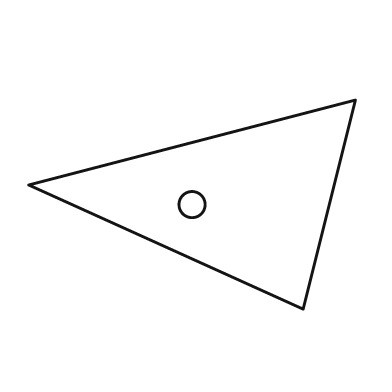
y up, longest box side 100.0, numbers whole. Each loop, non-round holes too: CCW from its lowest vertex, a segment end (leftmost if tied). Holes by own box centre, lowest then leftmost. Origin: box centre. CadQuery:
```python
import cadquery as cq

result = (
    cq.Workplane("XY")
    .moveTo(34.0, -32.0)
    .lineTo(50.0, 32.0)
    .lineTo(-50.0, 6.0)
    .close()
    .moveTo(0.0, 0.0)
    .circle(4.0)
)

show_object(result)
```